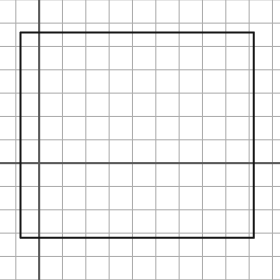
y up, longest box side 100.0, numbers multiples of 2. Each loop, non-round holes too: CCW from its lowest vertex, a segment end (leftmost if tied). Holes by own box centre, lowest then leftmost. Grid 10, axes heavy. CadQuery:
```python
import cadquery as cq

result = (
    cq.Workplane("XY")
    .moveTo(-8.0, -32.0)
    .lineTo(92.0, -32.0)
    .lineTo(92.0, 56.0)
    .lineTo(-8.0, 56.0)
    .close()
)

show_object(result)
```